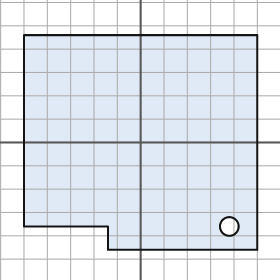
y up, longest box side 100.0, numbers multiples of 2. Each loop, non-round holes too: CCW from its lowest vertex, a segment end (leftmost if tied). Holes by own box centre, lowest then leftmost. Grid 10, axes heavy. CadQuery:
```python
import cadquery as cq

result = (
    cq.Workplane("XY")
    .moveTo(-14.0, -46.0)
    .lineTo(50.0, -46.0)
    .lineTo(50.0, 46.0)
    .lineTo(-50.0, 46.0)
    .lineTo(-50.0, -36.0)
    .lineTo(-14.0, -36.0)
    .close()
    .moveTo(38.0, -36.0)
    .circle(4.0)
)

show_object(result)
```